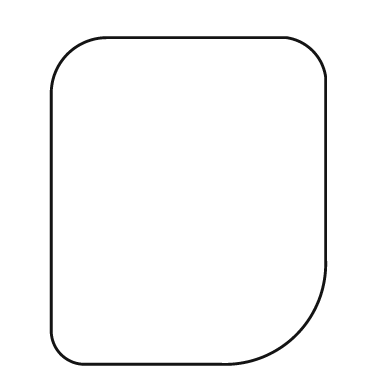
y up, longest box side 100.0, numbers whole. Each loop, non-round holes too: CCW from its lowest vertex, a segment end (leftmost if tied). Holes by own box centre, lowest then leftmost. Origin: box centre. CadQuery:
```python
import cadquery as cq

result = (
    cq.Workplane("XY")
    .moveTo(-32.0, -50.0)
    .lineTo(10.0, -50.0)
    .threePointArc((33.0, -41.0), (42.0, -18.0))
    .lineTo(42.0, 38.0)
    .threePointArc((38.0, 46.0), (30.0, 50.0))
    .lineTo(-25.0, 50.0)
    .threePointArc((-37.0, 45.0), (-42.0, 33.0))
    .lineTo(-42.0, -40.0)
    .threePointArc((-39.0, -47.0), (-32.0, -50.0))
    .close()
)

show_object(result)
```